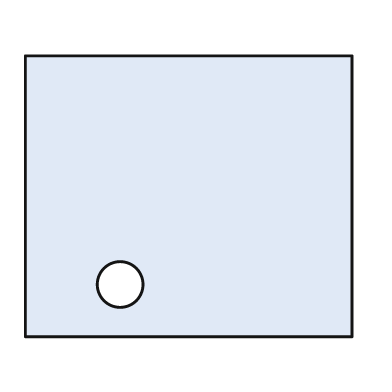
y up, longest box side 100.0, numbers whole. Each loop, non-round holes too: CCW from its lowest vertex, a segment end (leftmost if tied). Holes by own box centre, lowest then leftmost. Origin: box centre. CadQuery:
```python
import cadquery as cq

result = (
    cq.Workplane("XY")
    .moveTo(-50.0, -43.0)
    .lineTo(50.0, -43.0)
    .lineTo(50.0, 43.0)
    .lineTo(-50.0, 43.0)
    .close()
    .moveTo(-21.0, -27.0)
    .circle(7.0)
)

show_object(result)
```